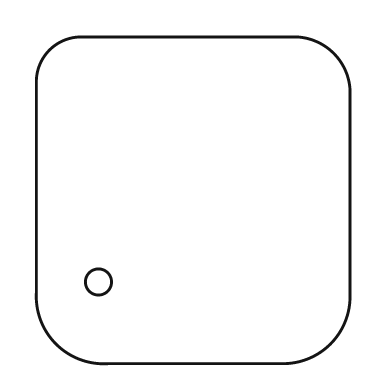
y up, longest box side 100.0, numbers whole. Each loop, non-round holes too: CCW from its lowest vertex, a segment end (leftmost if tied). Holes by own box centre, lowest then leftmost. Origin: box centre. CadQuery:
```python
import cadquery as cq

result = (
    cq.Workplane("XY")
    .moveTo(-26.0, -50.0)
    .lineTo(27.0, -50.0)
    .threePointArc((42.0, -44.0), (48.0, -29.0))
    .lineTo(48.0, 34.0)
    .threePointArc((43.0, 45.0), (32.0, 50.0))
    .lineTo(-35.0, 50.0)
    .threePointArc((-44.0, 46.0), (-48.0, 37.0))
    .lineTo(-48.0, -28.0)
    .threePointArc((-42.0, -44.0), (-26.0, -50.0))
    .close()
    .moveTo(-29.0, -25.0)
    .circle(4.0)
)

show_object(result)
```